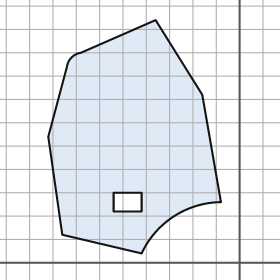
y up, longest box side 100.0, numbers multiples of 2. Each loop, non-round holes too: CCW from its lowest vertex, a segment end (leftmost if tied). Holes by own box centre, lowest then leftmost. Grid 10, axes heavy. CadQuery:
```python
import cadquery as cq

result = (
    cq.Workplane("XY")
    .moveTo(-42.0, 4.0)
    .threePointArc((-28.0, 20.0), (-8.0, 26.0))
    .lineTo(-16.0, 72.0)
    .lineTo(-36.0, 104.0)
    .lineTo(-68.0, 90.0)
    .threePointArc((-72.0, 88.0), (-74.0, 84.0))
    .lineTo(-82.0, 54.0)
    .lineTo(-76.0, 12.0)
    .close()
    .moveTo(-54.0, 22.0)
    .lineTo(-42.0, 22.0)
    .lineTo(-42.0, 30.0)
    .lineTo(-54.0, 30.0)
    .close()
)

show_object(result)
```